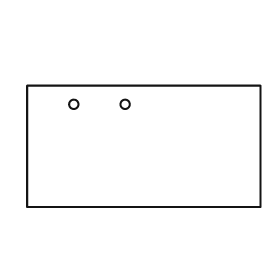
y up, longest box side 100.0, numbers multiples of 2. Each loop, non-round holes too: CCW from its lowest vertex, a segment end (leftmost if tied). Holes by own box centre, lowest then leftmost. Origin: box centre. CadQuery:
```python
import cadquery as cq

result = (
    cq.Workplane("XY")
    .moveTo(-50.0, -26.0)
    .lineTo(50.0, -26.0)
    .lineTo(50.0, 26.0)
    .lineTo(-50.0, 26.0)
    .close()
    .moveTo(-30.0, 18.0)
    .circle(2.0)
    .moveTo(-8.0, 18.0)
    .circle(2.0)
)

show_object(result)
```